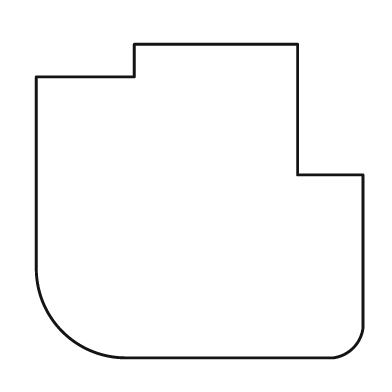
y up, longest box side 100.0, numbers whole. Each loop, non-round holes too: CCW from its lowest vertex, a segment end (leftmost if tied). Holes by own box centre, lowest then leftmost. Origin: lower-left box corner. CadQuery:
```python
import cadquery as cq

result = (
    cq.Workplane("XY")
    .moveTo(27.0, 0.0)
    .lineTo(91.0, 0.0)
    .threePointArc((97.0, 3.0), (100.0, 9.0))
    .lineTo(100.0, 56.0)
    .lineTo(80.0, 56.0)
    .lineTo(80.0, 96.0)
    .lineTo(30.0, 96.0)
    .lineTo(30.0, 86.0)
    .lineTo(0.0, 86.0)
    .lineTo(0.0, 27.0)
    .threePointArc((8.0, 8.0), (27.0, 0.0))
    .close()
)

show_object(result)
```